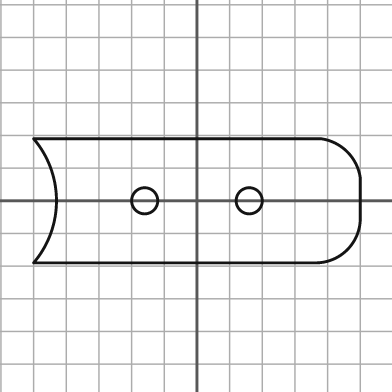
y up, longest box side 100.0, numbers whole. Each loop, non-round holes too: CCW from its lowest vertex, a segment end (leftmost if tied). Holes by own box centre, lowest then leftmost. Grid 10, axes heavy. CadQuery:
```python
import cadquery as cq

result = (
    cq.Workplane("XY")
    .moveTo(-50.0, -19.0)
    .lineTo(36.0, -19.0)
    .threePointArc((46.0, -15.0), (50.0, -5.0))
    .lineTo(50.0, 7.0)
    .threePointArc((46.0, 15.0), (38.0, 19.0))
    .lineTo(-50.0, 19.0)
    .threePointArc((-43.0, 0.0), (-50.0, -19.0))
    .close()
    .moveTo(-16.0, 0.0)
    .circle(4.0)
    .moveTo(16.0, 0.0)
    .circle(4.0)
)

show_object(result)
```